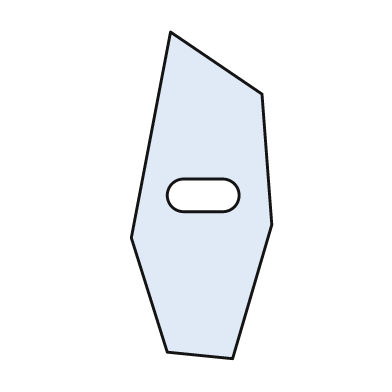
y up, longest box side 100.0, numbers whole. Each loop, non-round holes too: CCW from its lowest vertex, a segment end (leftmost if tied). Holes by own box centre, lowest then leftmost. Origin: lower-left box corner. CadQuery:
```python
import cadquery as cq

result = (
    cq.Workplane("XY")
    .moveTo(31.0, 0.0)
    .lineTo(43.0, 41.0)
    .lineTo(40.0, 81.0)
    .lineTo(12.0, 100.0)
    .lineTo(0.0, 37.0)
    .lineTo(11.0, 2.0)
    .close()
    .moveTo(16.0, 45.0)
    .lineTo(28.0, 45.0)
    .threePointArc((33.0, 50.0), (28.0, 55.0))
    .lineTo(16.0, 55.0)
    .threePointArc((11.0, 50.0), (16.0, 45.0))
    .close()
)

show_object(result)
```